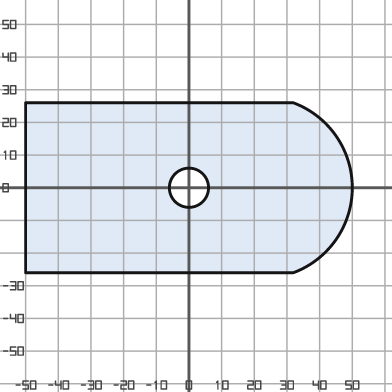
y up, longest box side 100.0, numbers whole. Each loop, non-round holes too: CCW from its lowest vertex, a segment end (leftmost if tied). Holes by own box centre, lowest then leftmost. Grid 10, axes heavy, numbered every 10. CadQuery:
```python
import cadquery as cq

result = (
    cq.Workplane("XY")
    .moveTo(-50.0, -26.0)
    .lineTo(32.0, -26.0)
    .threePointArc((50.0, 0.0), (32.0, 26.0))
    .lineTo(-50.0, 26.0)
    .close()
    .moveTo(0.0, 0.0)
    .circle(6.0)
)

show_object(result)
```